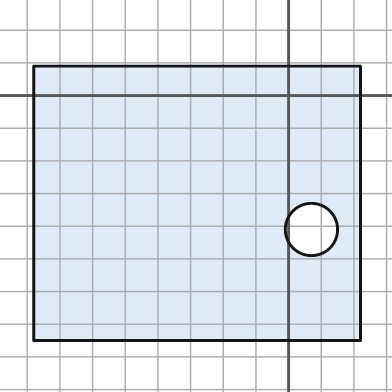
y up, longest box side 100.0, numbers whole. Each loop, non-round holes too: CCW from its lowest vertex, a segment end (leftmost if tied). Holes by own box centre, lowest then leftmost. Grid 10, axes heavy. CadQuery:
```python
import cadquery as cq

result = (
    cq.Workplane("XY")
    .moveTo(-78.0, -75.0)
    .lineTo(22.0, -75.0)
    .lineTo(22.0, 9.0)
    .lineTo(-78.0, 9.0)
    .close()
    .moveTo(7.0, -41.0)
    .circle(8.0)
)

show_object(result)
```